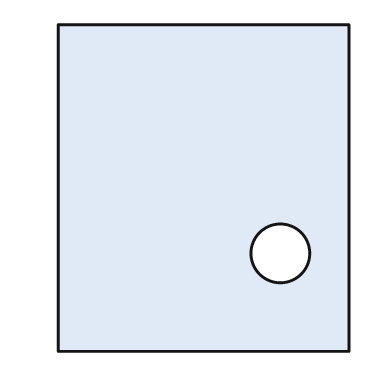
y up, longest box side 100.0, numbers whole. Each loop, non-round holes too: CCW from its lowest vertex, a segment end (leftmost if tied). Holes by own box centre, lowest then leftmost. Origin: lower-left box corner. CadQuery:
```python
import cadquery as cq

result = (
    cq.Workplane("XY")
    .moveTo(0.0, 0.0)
    .lineTo(89.0, 0.0)
    .lineTo(89.0, 100.0)
    .lineTo(0.0, 100.0)
    .close()
    .moveTo(68.0, 30.0)
    .circle(9.0)
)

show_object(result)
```